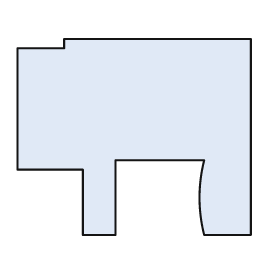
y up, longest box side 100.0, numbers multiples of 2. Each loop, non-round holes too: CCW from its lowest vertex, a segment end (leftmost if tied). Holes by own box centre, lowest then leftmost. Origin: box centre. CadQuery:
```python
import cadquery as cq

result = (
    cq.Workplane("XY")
    .moveTo(-22.0, -42.0)
    .lineTo(-8.0, -42.0)
    .lineTo(-8.0, -10.0)
    .lineTo(30.0, -10.0)
    .threePointArc((28.0, -26.0), (30.0, -42.0))
    .lineTo(50.0, -42.0)
    .lineTo(50.0, 42.0)
    .lineTo(-30.0, 42.0)
    .lineTo(-30.0, 38.0)
    .lineTo(-50.0, 38.0)
    .lineTo(-50.0, -14.0)
    .lineTo(-22.0, -14.0)
    .close()
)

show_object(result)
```